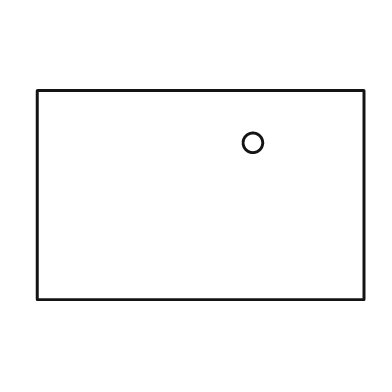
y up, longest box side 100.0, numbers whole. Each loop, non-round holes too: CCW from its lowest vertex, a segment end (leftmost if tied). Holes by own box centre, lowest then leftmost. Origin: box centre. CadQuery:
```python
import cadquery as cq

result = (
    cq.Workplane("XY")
    .moveTo(-50.0, -32.0)
    .lineTo(50.0, -32.0)
    .lineTo(50.0, 32.0)
    .lineTo(-50.0, 32.0)
    .close()
    .moveTo(16.0, 16.0)
    .circle(3.0)
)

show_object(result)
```